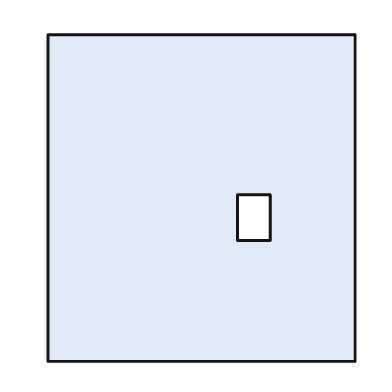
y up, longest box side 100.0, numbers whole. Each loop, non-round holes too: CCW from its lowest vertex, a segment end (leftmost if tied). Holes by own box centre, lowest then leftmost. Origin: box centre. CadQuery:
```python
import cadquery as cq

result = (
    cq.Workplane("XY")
    .moveTo(-47.0, -50.0)
    .lineTo(47.0, -50.0)
    .lineTo(47.0, 50.0)
    .lineTo(-47.0, 50.0)
    .close()
    .moveTo(11.0, -13.0)
    .lineTo(21.0, -13.0)
    .lineTo(21.0, 1.0)
    .lineTo(11.0, 1.0)
    .close()
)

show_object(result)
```